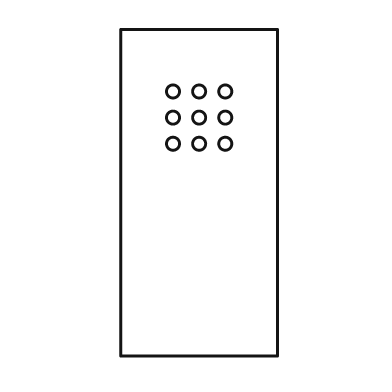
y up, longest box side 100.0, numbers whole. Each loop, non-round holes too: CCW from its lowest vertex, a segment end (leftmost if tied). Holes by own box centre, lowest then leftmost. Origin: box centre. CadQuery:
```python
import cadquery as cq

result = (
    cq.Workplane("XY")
    .moveTo(-24.0, -50.0)
    .lineTo(24.0, -50.0)
    .lineTo(24.0, 50.0)
    .lineTo(-24.0, 50.0)
    .close()
    .moveTo(-8.0, 15.0)
    .circle(2.0)
    .moveTo(0.0, 15.0)
    .circle(2.0)
    .moveTo(8.0, 15.0)
    .circle(2.0)
    .moveTo(-8.0, 23.0)
    .circle(2.0)
    .moveTo(0.0, 23.0)
    .circle(2.0)
    .moveTo(8.0, 23.0)
    .circle(2.0)
    .moveTo(-8.0, 31.0)
    .circle(2.0)
    .moveTo(0.0, 31.0)
    .circle(2.0)
    .moveTo(8.0, 31.0)
    .circle(2.0)
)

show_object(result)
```